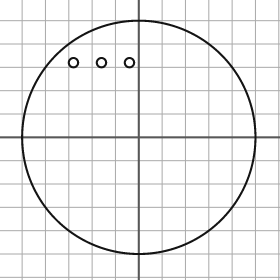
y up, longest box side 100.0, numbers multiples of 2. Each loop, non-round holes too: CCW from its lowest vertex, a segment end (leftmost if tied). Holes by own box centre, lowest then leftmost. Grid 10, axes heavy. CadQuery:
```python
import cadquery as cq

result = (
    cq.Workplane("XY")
    .moveTo(0.0, 0.0)
    .circle(50.0)
    .moveTo(-28.0, 32.0)
    .circle(2.0)
    .moveTo(-16.0, 32.0)
    .circle(2.0)
    .moveTo(-4.0, 32.0)
    .circle(2.0)
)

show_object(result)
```